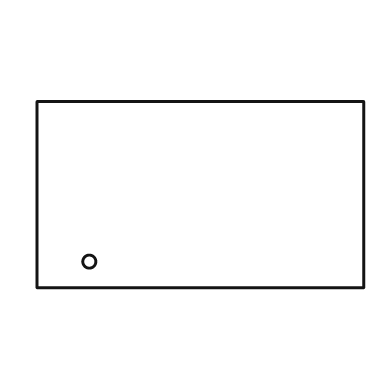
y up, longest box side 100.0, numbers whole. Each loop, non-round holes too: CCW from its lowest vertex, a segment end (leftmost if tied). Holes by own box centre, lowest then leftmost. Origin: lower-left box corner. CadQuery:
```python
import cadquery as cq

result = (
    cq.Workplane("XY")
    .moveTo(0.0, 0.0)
    .lineTo(100.0, 0.0)
    .lineTo(100.0, 57.0)
    .lineTo(0.0, 57.0)
    .close()
    .moveTo(16.0, 8.0)
    .circle(2.0)
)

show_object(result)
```